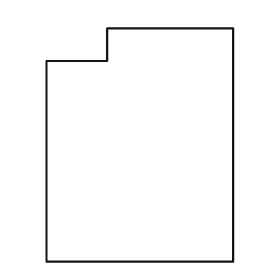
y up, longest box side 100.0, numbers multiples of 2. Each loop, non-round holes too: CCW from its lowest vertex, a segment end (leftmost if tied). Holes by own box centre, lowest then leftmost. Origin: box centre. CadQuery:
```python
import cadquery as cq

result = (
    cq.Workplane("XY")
    .moveTo(-40.0, -50.0)
    .lineTo(40.0, -50.0)
    .lineTo(40.0, 50.0)
    .lineTo(-14.0, 50.0)
    .lineTo(-14.0, 36.0)
    .lineTo(-40.0, 36.0)
    .close()
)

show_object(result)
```